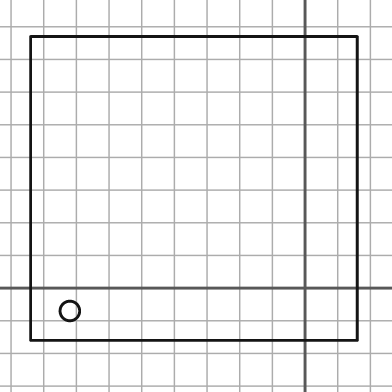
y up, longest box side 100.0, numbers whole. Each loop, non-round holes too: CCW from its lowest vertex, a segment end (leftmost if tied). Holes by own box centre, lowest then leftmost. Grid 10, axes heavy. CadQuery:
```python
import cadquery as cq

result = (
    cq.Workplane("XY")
    .moveTo(-84.0, -16.0)
    .lineTo(16.0, -16.0)
    .lineTo(16.0, 77.0)
    .lineTo(-84.0, 77.0)
    .close()
    .moveTo(-72.0, -7.0)
    .circle(3.0)
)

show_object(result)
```